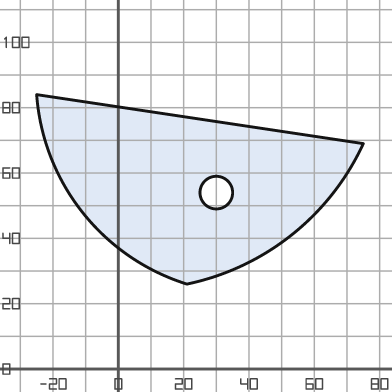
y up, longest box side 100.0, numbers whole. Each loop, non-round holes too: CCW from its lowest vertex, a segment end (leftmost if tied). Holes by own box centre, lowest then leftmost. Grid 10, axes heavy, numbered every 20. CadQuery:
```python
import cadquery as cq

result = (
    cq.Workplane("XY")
    .moveTo(21.0, 26.0)
    .threePointArc((53.0, 41.0), (75.0, 69.0))
    .lineTo(-25.0, 84.0)
    .threePointArc((-11.0, 48.0), (21.0, 26.0))
    .close()
    .moveTo(30.0, 54.0)
    .circle(5.0)
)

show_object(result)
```